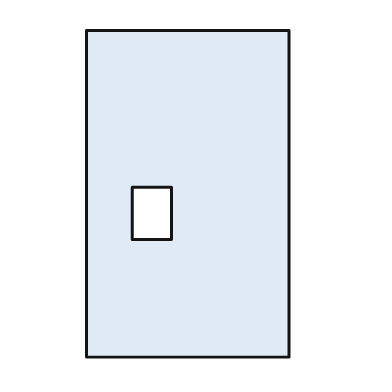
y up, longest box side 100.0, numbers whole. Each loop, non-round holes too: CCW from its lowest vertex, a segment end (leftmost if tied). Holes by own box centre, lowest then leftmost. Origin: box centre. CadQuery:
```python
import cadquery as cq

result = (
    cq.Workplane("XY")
    .moveTo(-31.0, -50.0)
    .lineTo(31.0, -50.0)
    .lineTo(31.0, 50.0)
    .lineTo(-31.0, 50.0)
    .close()
    .moveTo(-17.0, -14.0)
    .lineTo(-5.0, -14.0)
    .lineTo(-5.0, 2.0)
    .lineTo(-17.0, 2.0)
    .close()
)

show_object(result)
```